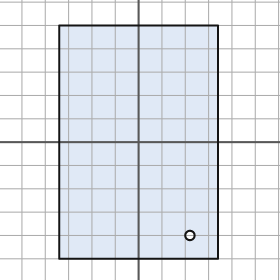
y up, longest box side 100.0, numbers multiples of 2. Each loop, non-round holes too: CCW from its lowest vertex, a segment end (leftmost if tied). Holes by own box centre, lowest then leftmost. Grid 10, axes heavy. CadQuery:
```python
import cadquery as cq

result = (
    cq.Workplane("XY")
    .moveTo(-34.0, -50.0)
    .lineTo(34.0, -50.0)
    .lineTo(34.0, 50.0)
    .lineTo(-34.0, 50.0)
    .close()
    .moveTo(22.0, -40.0)
    .circle(2.0)
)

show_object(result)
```